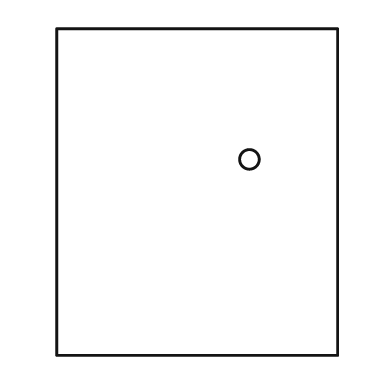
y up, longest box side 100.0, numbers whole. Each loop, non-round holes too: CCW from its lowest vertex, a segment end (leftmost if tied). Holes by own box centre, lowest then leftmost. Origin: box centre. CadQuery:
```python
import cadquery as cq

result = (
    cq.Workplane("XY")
    .moveTo(-43.0, -50.0)
    .lineTo(43.0, -50.0)
    .lineTo(43.0, 50.0)
    .lineTo(-43.0, 50.0)
    .close()
    .moveTo(16.0, 10.0)
    .circle(3.0)
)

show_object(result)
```